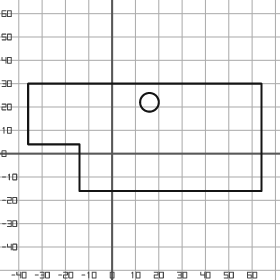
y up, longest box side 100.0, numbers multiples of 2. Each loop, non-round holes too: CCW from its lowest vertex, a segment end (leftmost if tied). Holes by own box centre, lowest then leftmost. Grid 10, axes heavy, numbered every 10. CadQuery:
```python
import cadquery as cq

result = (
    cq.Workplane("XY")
    .moveTo(-14.0, -16.0)
    .lineTo(64.0, -16.0)
    .lineTo(64.0, 30.0)
    .lineTo(-36.0, 30.0)
    .lineTo(-36.0, 4.0)
    .lineTo(-14.0, 4.0)
    .close()
    .moveTo(16.0, 22.0)
    .circle(4.0)
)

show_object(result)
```